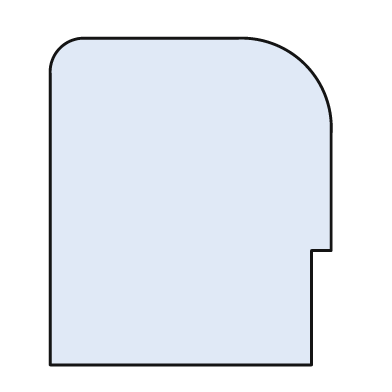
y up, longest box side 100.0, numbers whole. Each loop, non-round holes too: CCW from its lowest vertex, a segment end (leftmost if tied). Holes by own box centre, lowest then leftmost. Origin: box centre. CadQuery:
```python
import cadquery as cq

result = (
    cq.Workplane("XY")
    .moveTo(-43.0, -50.0)
    .lineTo(37.0, -50.0)
    .lineTo(37.0, -15.0)
    .lineTo(43.0, -15.0)
    .lineTo(43.0, 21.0)
    .threePointArc((35.0, 42.0), (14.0, 50.0))
    .lineTo(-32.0, 50.0)
    .threePointArc((-40.0, 47.0), (-43.0, 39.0))
    .close()
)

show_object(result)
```